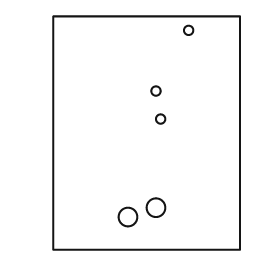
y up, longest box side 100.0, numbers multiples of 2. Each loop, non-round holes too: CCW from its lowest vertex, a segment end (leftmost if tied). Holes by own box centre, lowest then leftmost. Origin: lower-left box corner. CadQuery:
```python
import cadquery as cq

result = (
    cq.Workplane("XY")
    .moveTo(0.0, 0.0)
    .lineTo(80.0, 0.0)
    .lineTo(80.0, 100.0)
    .lineTo(0.0, 100.0)
    .close()
    .moveTo(32.0, 14.0)
    .circle(4.0)
    .moveTo(44.0, 18.0)
    .circle(4.0)
    .moveTo(46.0, 56.0)
    .circle(2.0)
    .moveTo(44.0, 68.0)
    .circle(2.0)
    .moveTo(58.0, 94.0)
    .circle(2.0)
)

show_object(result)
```